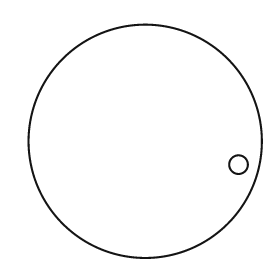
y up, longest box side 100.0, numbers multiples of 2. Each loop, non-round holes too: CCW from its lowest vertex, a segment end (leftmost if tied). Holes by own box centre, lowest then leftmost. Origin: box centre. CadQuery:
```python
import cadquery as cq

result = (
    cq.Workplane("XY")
    .moveTo(0.0, 0.0)
    .circle(50.0)
    .moveTo(40.0, -10.0)
    .circle(4.0)
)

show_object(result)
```